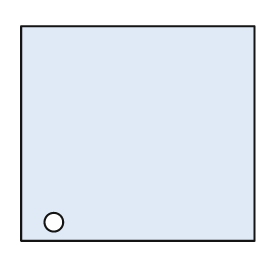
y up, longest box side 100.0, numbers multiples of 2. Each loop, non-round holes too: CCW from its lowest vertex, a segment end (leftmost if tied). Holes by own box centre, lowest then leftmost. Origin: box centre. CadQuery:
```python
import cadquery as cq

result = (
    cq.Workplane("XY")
    .moveTo(-50.0, -46.0)
    .lineTo(50.0, -46.0)
    .lineTo(50.0, 46.0)
    .lineTo(-50.0, 46.0)
    .close()
    .moveTo(-36.0, -38.0)
    .circle(4.0)
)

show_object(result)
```